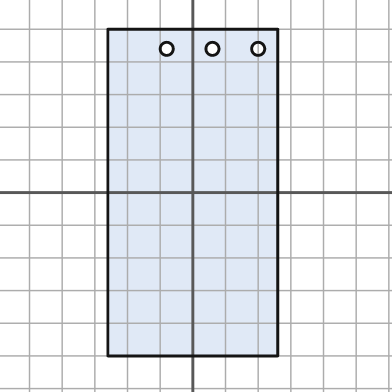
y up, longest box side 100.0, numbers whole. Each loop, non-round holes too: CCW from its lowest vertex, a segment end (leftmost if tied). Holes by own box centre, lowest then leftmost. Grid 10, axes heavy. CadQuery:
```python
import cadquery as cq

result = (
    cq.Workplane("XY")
    .moveTo(-26.0, -50.0)
    .lineTo(26.0, -50.0)
    .lineTo(26.0, 50.0)
    .lineTo(-26.0, 50.0)
    .close()
    .moveTo(-8.0, 44.0)
    .circle(2.0)
    .moveTo(6.0, 44.0)
    .circle(2.0)
    .moveTo(20.0, 44.0)
    .circle(2.0)
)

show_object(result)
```